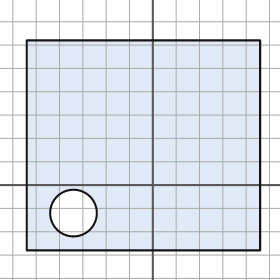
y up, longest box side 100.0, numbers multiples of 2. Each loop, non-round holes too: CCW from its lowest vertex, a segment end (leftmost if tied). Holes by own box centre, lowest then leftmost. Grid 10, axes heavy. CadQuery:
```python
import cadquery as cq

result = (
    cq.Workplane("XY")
    .moveTo(-54.0, -28.0)
    .lineTo(46.0, -28.0)
    .lineTo(46.0, 62.0)
    .lineTo(-54.0, 62.0)
    .close()
    .moveTo(-34.0, -12.0)
    .circle(10.0)
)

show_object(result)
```